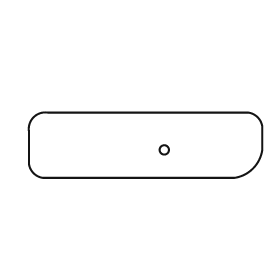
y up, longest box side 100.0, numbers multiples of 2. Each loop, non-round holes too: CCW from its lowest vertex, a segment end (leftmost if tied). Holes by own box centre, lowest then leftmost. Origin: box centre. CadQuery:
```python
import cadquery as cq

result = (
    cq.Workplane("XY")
    .moveTo(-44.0, -14.0)
    .lineTo(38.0, -14.0)
    .threePointArc((46.0, -10.0), (50.0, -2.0))
    .lineTo(50.0, 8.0)
    .threePointArc((48.0, 12.0), (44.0, 14.0))
    .lineTo(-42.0, 14.0)
    .threePointArc((-48.0, 12.0), (-50.0, 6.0))
    .lineTo(-50.0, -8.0)
    .threePointArc((-48.0, -12.0), (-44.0, -14.0))
    .close()
    .moveTo(8.0, -2.0)
    .circle(2.0)
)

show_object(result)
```